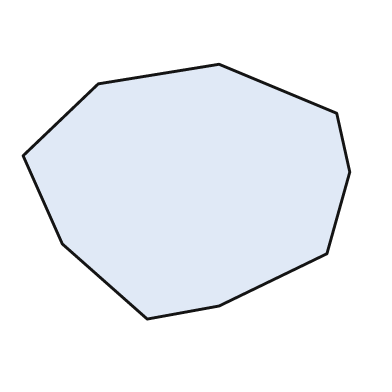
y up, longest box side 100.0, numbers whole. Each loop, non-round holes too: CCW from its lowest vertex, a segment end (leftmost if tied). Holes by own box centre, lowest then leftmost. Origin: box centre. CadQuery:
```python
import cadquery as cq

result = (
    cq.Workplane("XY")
    .moveTo(-12.0, -39.0)
    .lineTo(10.0, -35.0)
    .lineTo(43.0, -19.0)
    .lineTo(50.0, 6.0)
    .lineTo(46.0, 24.0)
    .lineTo(10.0, 39.0)
    .lineTo(-27.0, 33.0)
    .lineTo(-50.0, 11.0)
    .lineTo(-38.0, -16.0)
    .close()
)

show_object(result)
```